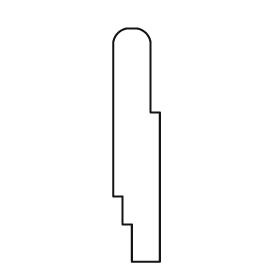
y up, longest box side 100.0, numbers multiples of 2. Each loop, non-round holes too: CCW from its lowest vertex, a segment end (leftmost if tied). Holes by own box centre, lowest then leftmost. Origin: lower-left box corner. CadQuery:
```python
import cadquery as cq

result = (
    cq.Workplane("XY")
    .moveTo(8.0, 0.0)
    .lineTo(20.0, 0.0)
    .lineTo(20.0, 64.0)
    .lineTo(16.0, 64.0)
    .lineTo(16.0, 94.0)
    .threePointArc((14.0, 98.0), (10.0, 100.0))
    .lineTo(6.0, 100.0)
    .threePointArc((2.0, 98.0), (0.0, 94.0))
    .lineTo(0.0, 28.0)
    .lineTo(4.0, 28.0)
    .lineTo(4.0, 16.0)
    .lineTo(8.0, 16.0)
    .close()
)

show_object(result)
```